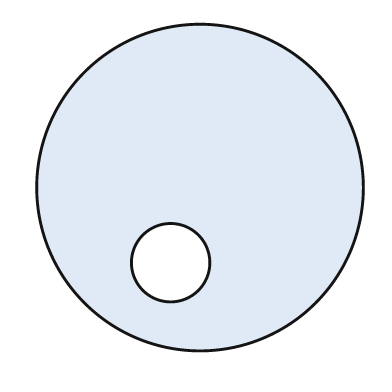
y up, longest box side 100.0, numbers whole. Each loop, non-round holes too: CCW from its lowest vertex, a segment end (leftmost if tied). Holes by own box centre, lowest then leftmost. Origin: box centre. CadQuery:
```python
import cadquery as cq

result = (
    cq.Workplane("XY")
    .moveTo(0.0, 0.0)
    .circle(50.0)
    .moveTo(-9.0, -23.0)
    .circle(12.0)
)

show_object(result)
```